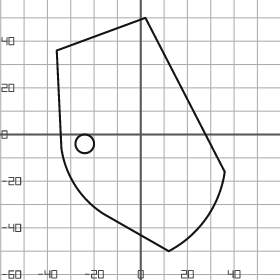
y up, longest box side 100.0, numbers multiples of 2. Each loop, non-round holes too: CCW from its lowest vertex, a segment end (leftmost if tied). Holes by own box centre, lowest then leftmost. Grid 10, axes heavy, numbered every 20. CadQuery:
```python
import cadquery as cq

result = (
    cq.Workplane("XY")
    .moveTo(12.0, -50.0)
    .threePointArc((28.0, -36.0), (36.0, -16.0))
    .lineTo(2.0, 50.0)
    .lineTo(-36.0, 36.0)
    .lineTo(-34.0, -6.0)
    .threePointArc((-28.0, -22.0), (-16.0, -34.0))
    .close()
    .moveTo(-24.0, -4.0)
    .circle(4.0)
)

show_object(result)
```